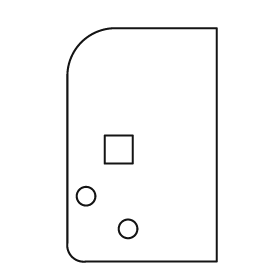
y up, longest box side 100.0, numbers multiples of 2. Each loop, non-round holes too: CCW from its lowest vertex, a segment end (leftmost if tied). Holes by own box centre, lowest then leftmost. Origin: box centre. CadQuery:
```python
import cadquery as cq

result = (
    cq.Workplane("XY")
    .moveTo(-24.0, -50.0)
    .lineTo(32.0, -50.0)
    .lineTo(32.0, 50.0)
    .lineTo(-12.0, 50.0)
    .threePointArc((-26.0, 44.0), (-32.0, 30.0))
    .lineTo(-32.0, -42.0)
    .threePointArc((-30.0, -48.0), (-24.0, -50.0))
    .close()
    .moveTo(-6.0, -36.0)
    .circle(4.0)
    .moveTo(-24.0, -22.0)
    .circle(4.0)
    .moveTo(-16.0, -8.0)
    .lineTo(-4.0, -8.0)
    .lineTo(-4.0, 4.0)
    .lineTo(-16.0, 4.0)
    .close()
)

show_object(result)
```